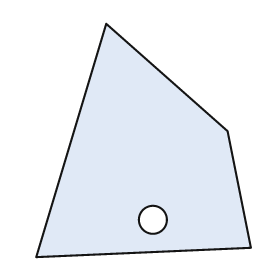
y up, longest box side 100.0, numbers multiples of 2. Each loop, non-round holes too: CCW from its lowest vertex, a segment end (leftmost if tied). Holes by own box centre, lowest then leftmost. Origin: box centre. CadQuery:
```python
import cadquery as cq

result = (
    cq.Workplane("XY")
    .moveTo(-46.0, -50.0)
    .lineTo(46.0, -46.0)
    .lineTo(36.0, 4.0)
    .lineTo(-16.0, 50.0)
    .close()
    .moveTo(4.0, -34.0)
    .circle(6.0)
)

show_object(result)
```